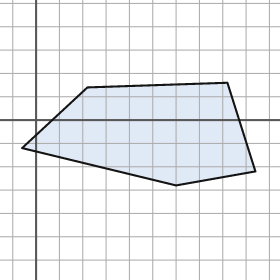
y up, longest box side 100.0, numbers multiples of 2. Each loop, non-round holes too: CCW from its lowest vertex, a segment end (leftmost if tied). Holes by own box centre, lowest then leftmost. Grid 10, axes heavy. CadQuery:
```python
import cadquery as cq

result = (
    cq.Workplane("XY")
    .moveTo(60.0, -28.0)
    .lineTo(94.0, -22.0)
    .lineTo(82.0, 16.0)
    .lineTo(22.0, 14.0)
    .lineTo(-6.0, -12.0)
    .close()
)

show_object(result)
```